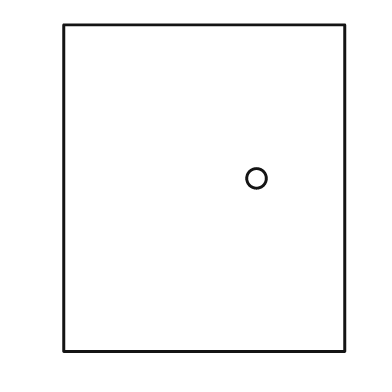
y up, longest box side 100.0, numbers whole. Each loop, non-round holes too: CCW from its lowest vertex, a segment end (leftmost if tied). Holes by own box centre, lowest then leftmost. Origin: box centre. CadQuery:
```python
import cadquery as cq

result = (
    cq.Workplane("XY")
    .moveTo(-43.0, -50.0)
    .lineTo(43.0, -50.0)
    .lineTo(43.0, 50.0)
    .lineTo(-43.0, 50.0)
    .close()
    .moveTo(16.0, 3.0)
    .circle(3.0)
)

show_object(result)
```